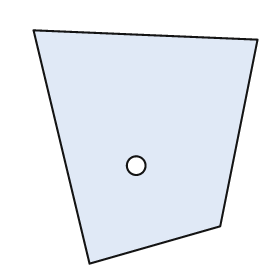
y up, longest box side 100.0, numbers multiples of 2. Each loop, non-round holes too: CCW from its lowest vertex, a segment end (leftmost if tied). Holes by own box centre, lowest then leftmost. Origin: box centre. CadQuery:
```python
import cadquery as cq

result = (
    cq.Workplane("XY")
    .moveTo(-24.0, -50.0)
    .lineTo(32.0, -34.0)
    .lineTo(48.0, 46.0)
    .lineTo(-48.0, 50.0)
    .close()
    .moveTo(-4.0, -8.0)
    .circle(4.0)
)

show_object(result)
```